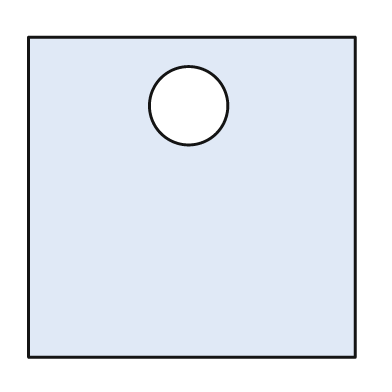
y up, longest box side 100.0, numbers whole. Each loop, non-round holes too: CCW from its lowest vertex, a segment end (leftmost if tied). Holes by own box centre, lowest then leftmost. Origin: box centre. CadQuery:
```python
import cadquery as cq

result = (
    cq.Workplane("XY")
    .moveTo(-50.0, -49.0)
    .lineTo(50.0, -49.0)
    .lineTo(50.0, 49.0)
    .lineTo(-50.0, 49.0)
    .close()
    .moveTo(-1.0, 28.0)
    .circle(12.0)
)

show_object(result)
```